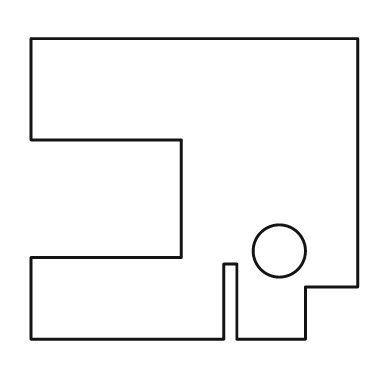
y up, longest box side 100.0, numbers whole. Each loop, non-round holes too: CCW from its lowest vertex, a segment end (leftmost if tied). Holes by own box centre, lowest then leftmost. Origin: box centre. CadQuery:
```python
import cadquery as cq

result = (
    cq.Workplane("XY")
    .moveTo(-50.0, -46.0)
    .lineTo(9.0, -46.0)
    .lineTo(9.0, -23.0)
    .lineTo(13.0, -23.0)
    .lineTo(13.0, -46.0)
    .lineTo(34.0, -46.0)
    .lineTo(34.0, -30.0)
    .lineTo(50.0, -30.0)
    .lineTo(50.0, 46.0)
    .lineTo(-50.0, 46.0)
    .lineTo(-50.0, 15.0)
    .lineTo(-4.0, 15.0)
    .lineTo(-4.0, -21.0)
    .lineTo(-50.0, -21.0)
    .close()
    .moveTo(26.0, -19.0)
    .circle(8.0)
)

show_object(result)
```